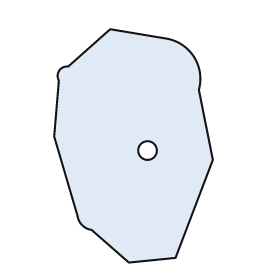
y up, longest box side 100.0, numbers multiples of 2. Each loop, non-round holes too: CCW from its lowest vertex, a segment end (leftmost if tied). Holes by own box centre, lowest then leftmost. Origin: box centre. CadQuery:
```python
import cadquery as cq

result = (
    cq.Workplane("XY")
    .moveTo(-2.0, -50.0)
    .lineTo(18.0, -48.0)
    .lineTo(34.0, -6.0)
    .lineTo(28.0, 24.0)
    .threePointArc((26.0, 38.0), (14.0, 46.0))
    .lineTo(-10.0, 50.0)
    .lineTo(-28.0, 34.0)
    .threePointArc((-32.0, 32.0), (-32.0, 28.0))
    .lineTo(-34.0, 4.0)
    .lineTo(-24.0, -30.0)
    .threePointArc((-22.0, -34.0), (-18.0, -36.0))
    .close()
    .moveTo(6.0, -2.0)
    .circle(4.0)
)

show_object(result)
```